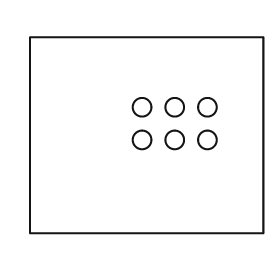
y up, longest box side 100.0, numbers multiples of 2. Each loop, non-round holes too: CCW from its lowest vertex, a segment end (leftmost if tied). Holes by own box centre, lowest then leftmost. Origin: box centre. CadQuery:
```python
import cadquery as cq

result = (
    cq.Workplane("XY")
    .moveTo(-50.0, -42.0)
    .lineTo(50.0, -42.0)
    .lineTo(50.0, 42.0)
    .lineTo(-50.0, 42.0)
    .close()
    .moveTo(-2.0, -2.0)
    .circle(4.0)
    .moveTo(12.0, -2.0)
    .circle(4.0)
    .moveTo(26.0, -2.0)
    .circle(4.0)
    .moveTo(-2.0, 12.0)
    .circle(4.0)
    .moveTo(12.0, 12.0)
    .circle(4.0)
    .moveTo(26.0, 12.0)
    .circle(4.0)
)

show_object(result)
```